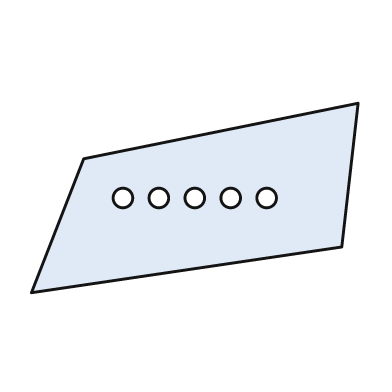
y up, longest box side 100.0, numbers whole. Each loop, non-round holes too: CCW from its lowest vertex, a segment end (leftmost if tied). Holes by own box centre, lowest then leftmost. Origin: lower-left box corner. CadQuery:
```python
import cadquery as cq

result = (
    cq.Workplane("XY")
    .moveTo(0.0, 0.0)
    .lineTo(95.0, 14.0)
    .lineTo(100.0, 58.0)
    .lineTo(16.0, 41.0)
    .close()
    .moveTo(28.0, 29.0)
    .circle(3.0)
    .moveTo(39.0, 29.0)
    .circle(3.0)
    .moveTo(50.0, 29.0)
    .circle(3.0)
    .moveTo(61.0, 29.0)
    .circle(3.0)
    .moveTo(72.0, 29.0)
    .circle(3.0)
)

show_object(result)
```